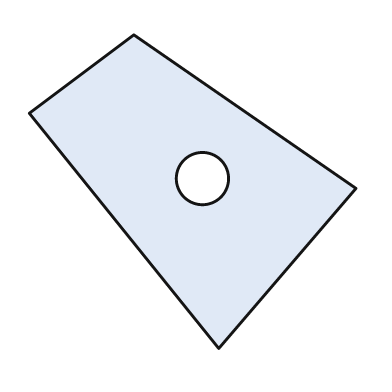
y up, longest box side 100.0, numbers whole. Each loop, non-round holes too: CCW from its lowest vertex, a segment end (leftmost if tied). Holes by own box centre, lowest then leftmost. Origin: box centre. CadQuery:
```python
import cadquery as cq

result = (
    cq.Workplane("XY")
    .moveTo(8.0, -48.0)
    .lineTo(50.0, 1.0)
    .lineTo(-18.0, 48.0)
    .lineTo(-50.0, 24.0)
    .close()
    .moveTo(3.0, 4.0)
    .circle(8.0)
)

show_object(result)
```